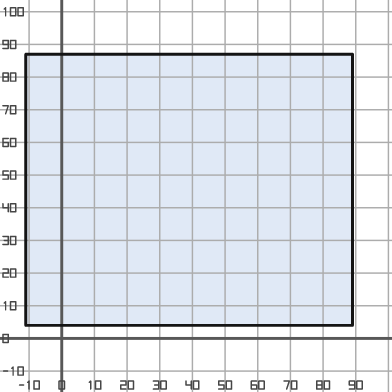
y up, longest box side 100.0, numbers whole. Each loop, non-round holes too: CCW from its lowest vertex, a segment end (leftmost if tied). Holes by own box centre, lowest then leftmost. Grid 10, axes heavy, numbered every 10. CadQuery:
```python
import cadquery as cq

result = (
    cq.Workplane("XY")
    .moveTo(-11.0, 4.0)
    .lineTo(89.0, 4.0)
    .lineTo(89.0, 87.0)
    .lineTo(-11.0, 87.0)
    .close()
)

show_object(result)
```